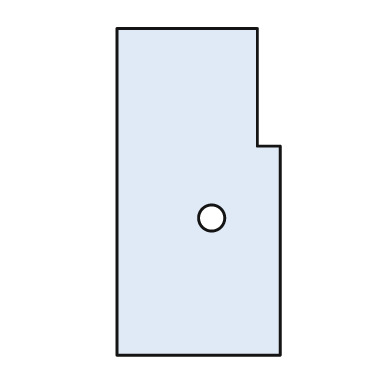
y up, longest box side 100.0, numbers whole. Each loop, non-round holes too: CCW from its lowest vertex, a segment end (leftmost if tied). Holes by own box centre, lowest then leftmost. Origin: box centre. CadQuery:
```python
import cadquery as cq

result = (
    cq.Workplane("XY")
    .moveTo(-25.0, -50.0)
    .lineTo(25.0, -50.0)
    .lineTo(25.0, 14.0)
    .lineTo(18.0, 14.0)
    .lineTo(18.0, 50.0)
    .lineTo(-25.0, 50.0)
    .close()
    .moveTo(4.0, -8.0)
    .circle(4.0)
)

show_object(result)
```